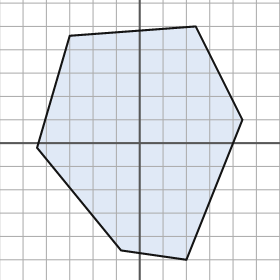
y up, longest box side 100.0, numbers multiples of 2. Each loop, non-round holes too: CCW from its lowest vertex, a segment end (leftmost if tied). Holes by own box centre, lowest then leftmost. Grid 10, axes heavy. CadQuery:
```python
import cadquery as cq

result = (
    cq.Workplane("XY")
    .moveTo(20.0, -50.0)
    .lineTo(44.0, 10.0)
    .lineTo(24.0, 50.0)
    .lineTo(-30.0, 46.0)
    .lineTo(-44.0, -2.0)
    .lineTo(-8.0, -46.0)
    .close()
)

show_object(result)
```